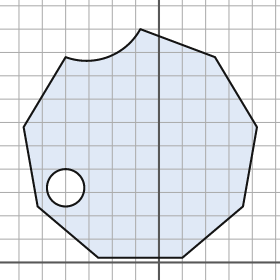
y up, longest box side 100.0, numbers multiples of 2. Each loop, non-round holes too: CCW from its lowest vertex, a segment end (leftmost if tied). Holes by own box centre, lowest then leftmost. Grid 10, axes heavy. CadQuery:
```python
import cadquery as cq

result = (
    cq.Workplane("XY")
    .moveTo(-26.0, 2.0)
    .lineTo(10.0, 2.0)
    .lineTo(36.0, 24.0)
    .lineTo(42.0, 58.0)
    .lineTo(24.0, 88.0)
    .lineTo(-8.0, 100.0)
    .threePointArc((-22.0, 88.0), (-40.0, 88.0))
    .lineTo(-58.0, 58.0)
    .lineTo(-52.0, 24.0)
    .close()
    .moveTo(-40.0, 32.0)
    .circle(8.0)
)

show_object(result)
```